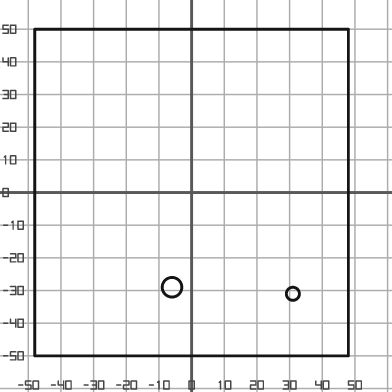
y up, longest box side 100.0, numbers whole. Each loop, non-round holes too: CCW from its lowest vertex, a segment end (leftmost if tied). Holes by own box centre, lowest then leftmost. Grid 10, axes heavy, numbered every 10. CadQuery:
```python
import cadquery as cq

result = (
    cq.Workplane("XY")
    .moveTo(-48.0, -50.0)
    .lineTo(48.0, -50.0)
    .lineTo(48.0, 50.0)
    .lineTo(-48.0, 50.0)
    .close()
    .moveTo(31.0, -31.0)
    .circle(2.0)
    .moveTo(-6.0, -29.0)
    .circle(3.0)
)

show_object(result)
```